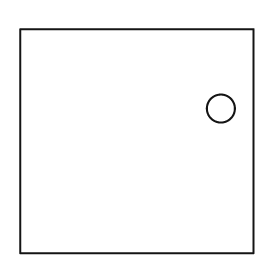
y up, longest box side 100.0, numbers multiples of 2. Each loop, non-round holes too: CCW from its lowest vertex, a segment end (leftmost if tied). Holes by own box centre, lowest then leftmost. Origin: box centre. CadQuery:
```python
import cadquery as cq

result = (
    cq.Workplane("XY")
    .moveTo(-50.0, -48.0)
    .lineTo(50.0, -48.0)
    .lineTo(50.0, 48.0)
    .lineTo(-50.0, 48.0)
    .close()
    .moveTo(36.0, 14.0)
    .circle(6.0)
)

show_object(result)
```